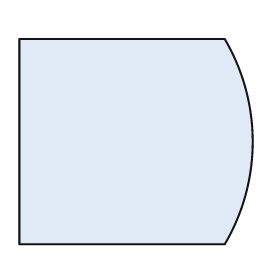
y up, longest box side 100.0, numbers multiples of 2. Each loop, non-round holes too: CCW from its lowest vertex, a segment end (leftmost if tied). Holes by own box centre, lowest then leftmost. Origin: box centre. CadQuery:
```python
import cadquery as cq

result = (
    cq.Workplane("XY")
    .moveTo(-50.0, -44.0)
    .lineTo(38.0, -44.0)
    .threePointArc((50.0, 0.0), (38.0, 44.0))
    .lineTo(-50.0, 44.0)
    .close()
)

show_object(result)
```